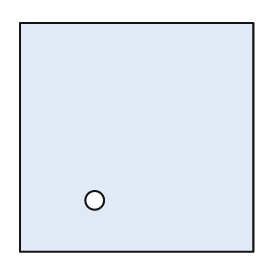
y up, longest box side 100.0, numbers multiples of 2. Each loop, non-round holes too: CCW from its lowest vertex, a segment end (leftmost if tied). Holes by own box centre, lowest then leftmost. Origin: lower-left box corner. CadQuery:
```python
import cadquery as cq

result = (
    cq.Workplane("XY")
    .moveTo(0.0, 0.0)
    .lineTo(100.0, 0.0)
    .lineTo(100.0, 98.0)
    .lineTo(0.0, 98.0)
    .close()
    .moveTo(32.0, 22.0)
    .circle(4.0)
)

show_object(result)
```